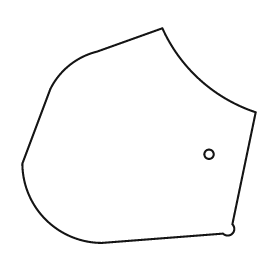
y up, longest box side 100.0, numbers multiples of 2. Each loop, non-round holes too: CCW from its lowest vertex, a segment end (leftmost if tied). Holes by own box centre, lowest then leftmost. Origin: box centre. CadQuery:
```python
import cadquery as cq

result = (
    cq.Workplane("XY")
    .moveTo(-16.0, -46.0)
    .lineTo(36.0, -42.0)
    .threePointArc((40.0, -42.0), (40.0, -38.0))
    .lineTo(50.0, 10.0)
    .threePointArc((26.0, 24.0), (10.0, 46.0))
    .lineTo(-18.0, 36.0)
    .threePointArc((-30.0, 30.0), (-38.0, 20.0))
    .lineTo(-50.0, -12.0)
    .threePointArc((-40.0, -36.0), (-16.0, -46.0))
    .close()
    .moveTo(30.0, -8.0)
    .circle(2.0)
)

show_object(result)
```